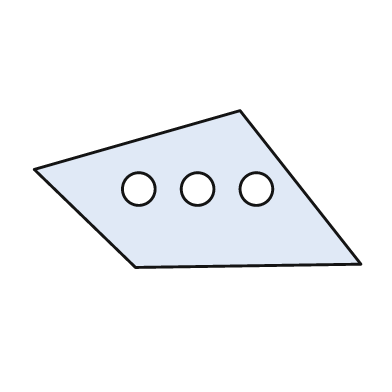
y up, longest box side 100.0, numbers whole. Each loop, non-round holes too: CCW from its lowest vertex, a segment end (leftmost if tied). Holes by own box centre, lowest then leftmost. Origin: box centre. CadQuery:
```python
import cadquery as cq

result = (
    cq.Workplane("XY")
    .moveTo(-19.0, -24.0)
    .lineTo(50.0, -23.0)
    .lineTo(13.0, 24.0)
    .lineTo(-50.0, 6.0)
    .close()
    .moveTo(-18.0, 0.0)
    .circle(5.0)
    .moveTo(0.0, 0.0)
    .circle(5.0)
    .moveTo(18.0, 0.0)
    .circle(5.0)
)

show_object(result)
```